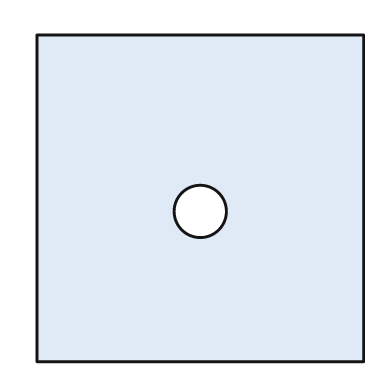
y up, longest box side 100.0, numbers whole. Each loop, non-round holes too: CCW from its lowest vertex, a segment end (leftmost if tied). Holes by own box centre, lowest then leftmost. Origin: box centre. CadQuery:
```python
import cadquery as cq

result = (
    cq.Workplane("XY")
    .moveTo(-50.0, -50.0)
    .lineTo(50.0, -50.0)
    .lineTo(50.0, 50.0)
    .lineTo(-50.0, 50.0)
    .close()
    .moveTo(0.0, -4.0)
    .circle(8.0)
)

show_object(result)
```